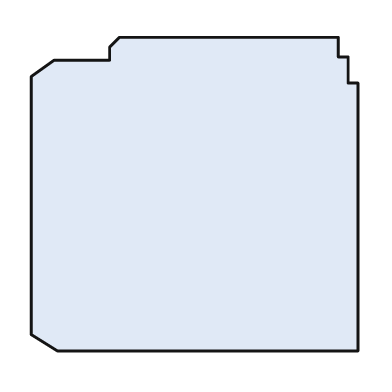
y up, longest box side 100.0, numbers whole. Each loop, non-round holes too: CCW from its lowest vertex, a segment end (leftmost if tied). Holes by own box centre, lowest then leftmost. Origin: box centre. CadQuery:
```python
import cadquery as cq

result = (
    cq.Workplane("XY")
    .moveTo(-42.0, -48.0)
    .lineTo(50.0, -48.0)
    .lineTo(50.0, 34.0)
    .lineTo(47.0, 34.0)
    .lineTo(47.0, 42.0)
    .lineTo(44.0, 42.0)
    .lineTo(44.0, 48.0)
    .lineTo(-23.0, 48.0)
    .lineTo(-26.0, 45.0)
    .lineTo(-26.0, 41.0)
    .lineTo(-43.0, 41.0)
    .lineTo(-50.0, 36.0)
    .lineTo(-50.0, -43.0)
    .close()
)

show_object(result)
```